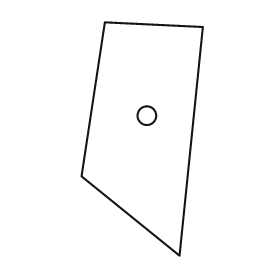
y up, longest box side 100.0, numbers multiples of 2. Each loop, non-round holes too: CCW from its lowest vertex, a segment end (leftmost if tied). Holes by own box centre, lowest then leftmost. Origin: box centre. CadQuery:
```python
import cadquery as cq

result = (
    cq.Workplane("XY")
    .moveTo(16.0, -50.0)
    .lineTo(26.0, 48.0)
    .lineTo(-16.0, 50.0)
    .lineTo(-26.0, -16.0)
    .close()
    .moveTo(2.0, 10.0)
    .circle(4.0)
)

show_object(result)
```